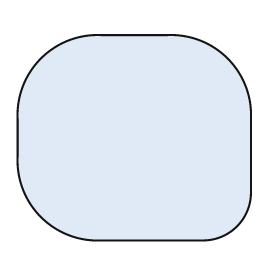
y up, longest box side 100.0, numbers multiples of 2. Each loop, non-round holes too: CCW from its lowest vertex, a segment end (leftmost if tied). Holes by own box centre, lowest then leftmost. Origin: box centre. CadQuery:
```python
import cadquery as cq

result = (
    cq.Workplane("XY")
    .moveTo(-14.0, -44.0)
    .lineTo(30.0, -44.0)
    .threePointArc((44.0, -38.0), (50.0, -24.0))
    .lineTo(50.0, 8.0)
    .threePointArc((40.0, 34.0), (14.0, 44.0))
    .lineTo(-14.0, 44.0)
    .threePointArc((-40.0, 34.0), (-50.0, 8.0))
    .lineTo(-50.0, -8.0)
    .threePointArc((-40.0, -34.0), (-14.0, -44.0))
    .close()
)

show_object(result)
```